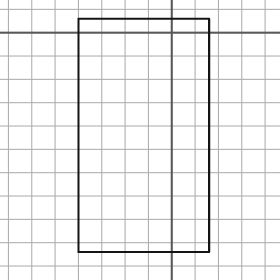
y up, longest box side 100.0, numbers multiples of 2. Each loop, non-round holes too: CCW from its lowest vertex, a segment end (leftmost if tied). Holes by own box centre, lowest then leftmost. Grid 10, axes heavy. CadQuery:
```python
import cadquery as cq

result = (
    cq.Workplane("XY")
    .moveTo(-40.0, -94.0)
    .lineTo(16.0, -94.0)
    .lineTo(16.0, 6.0)
    .lineTo(-40.0, 6.0)
    .close()
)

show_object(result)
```